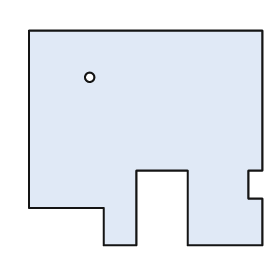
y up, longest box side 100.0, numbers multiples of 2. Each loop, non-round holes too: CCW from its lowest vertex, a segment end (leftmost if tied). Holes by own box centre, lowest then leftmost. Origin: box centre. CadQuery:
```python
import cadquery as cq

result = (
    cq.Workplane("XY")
    .moveTo(-18.0, -46.0)
    .lineTo(-4.0, -46.0)
    .lineTo(-4.0, -14.0)
    .lineTo(18.0, -14.0)
    .lineTo(18.0, -46.0)
    .lineTo(50.0, -46.0)
    .lineTo(50.0, -26.0)
    .lineTo(44.0, -26.0)
    .lineTo(44.0, -14.0)
    .lineTo(50.0, -14.0)
    .lineTo(50.0, 46.0)
    .lineTo(-50.0, 46.0)
    .lineTo(-50.0, -30.0)
    .lineTo(-18.0, -30.0)
    .close()
    .moveTo(-24.0, 26.0)
    .circle(2.0)
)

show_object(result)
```